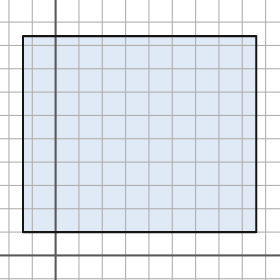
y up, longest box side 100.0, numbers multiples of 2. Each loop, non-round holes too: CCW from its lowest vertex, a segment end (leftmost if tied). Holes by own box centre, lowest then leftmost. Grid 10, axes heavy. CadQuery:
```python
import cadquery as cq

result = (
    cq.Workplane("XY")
    .moveTo(-14.0, 10.0)
    .lineTo(86.0, 10.0)
    .lineTo(86.0, 94.0)
    .lineTo(-14.0, 94.0)
    .close()
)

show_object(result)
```